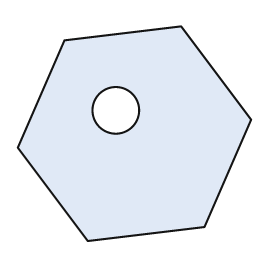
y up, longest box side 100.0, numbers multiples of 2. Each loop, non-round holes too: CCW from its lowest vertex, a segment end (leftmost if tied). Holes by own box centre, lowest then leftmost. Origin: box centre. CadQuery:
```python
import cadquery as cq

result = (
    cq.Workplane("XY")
    .moveTo(-20.0, -46.0)
    .lineTo(30.0, -40.0)
    .lineTo(50.0, 6.0)
    .lineTo(20.0, 46.0)
    .lineTo(-30.0, 40.0)
    .lineTo(-50.0, -6.0)
    .close()
    .moveTo(-8.0, 10.0)
    .circle(10.0)
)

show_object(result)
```